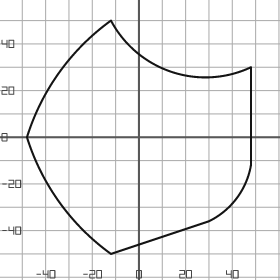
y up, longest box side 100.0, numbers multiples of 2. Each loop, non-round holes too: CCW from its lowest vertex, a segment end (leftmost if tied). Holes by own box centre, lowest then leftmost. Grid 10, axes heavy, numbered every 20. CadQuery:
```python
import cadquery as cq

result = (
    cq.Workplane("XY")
    .moveTo(-12.0, -50.0)
    .lineTo(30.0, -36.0)
    .threePointArc((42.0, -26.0), (48.0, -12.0))
    .lineTo(48.0, 30.0)
    .threePointArc((14.0, 28.0), (-12.0, 50.0))
    .threePointArc((-34.0, 28.0), (-48.0, 0.0))
    .threePointArc((-34.0, -28.0), (-12.0, -50.0))
    .close()
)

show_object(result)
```